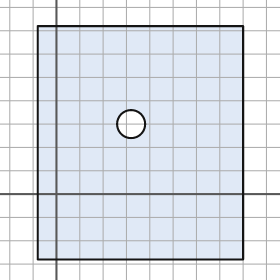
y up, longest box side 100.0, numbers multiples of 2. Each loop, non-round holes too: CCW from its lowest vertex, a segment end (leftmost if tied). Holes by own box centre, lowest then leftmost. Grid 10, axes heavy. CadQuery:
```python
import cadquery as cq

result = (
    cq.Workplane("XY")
    .moveTo(-8.0, -28.0)
    .lineTo(80.0, -28.0)
    .lineTo(80.0, 72.0)
    .lineTo(-8.0, 72.0)
    .close()
    .moveTo(32.0, 30.0)
    .circle(6.0)
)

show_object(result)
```